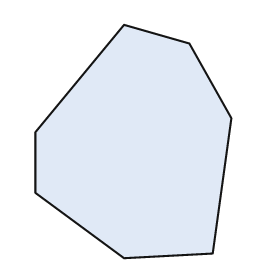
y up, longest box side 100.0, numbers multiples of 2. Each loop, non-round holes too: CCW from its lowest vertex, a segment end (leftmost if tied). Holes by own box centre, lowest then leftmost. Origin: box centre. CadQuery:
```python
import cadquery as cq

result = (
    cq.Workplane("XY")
    .moveTo(-4.0, -50.0)
    .lineTo(34.0, -48.0)
    .lineTo(42.0, 10.0)
    .lineTo(24.0, 42.0)
    .lineTo(-4.0, 50.0)
    .lineTo(-42.0, 4.0)
    .lineTo(-42.0, -22.0)
    .close()
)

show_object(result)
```